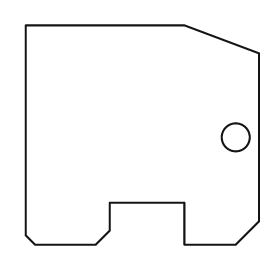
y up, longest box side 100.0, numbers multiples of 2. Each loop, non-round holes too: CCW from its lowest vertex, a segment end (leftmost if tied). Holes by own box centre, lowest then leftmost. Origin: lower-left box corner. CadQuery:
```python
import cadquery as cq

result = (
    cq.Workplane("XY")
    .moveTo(4.0, 0.0)
    .lineTo(30.0, 0.0)
    .lineTo(36.0, 6.0)
    .lineTo(36.0, 18.0)
    .lineTo(68.0, 18.0)
    .lineTo(68.0, 0.0)
    .lineTo(90.0, 0.0)
    .lineTo(100.0, 10.0)
    .lineTo(100.0, 82.0)
    .lineTo(68.0, 94.0)
    .lineTo(0.0, 94.0)
    .lineTo(0.0, 4.0)
    .close()
    .moveTo(90.0, 46.0)
    .circle(6.0)
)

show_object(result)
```